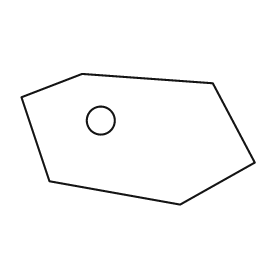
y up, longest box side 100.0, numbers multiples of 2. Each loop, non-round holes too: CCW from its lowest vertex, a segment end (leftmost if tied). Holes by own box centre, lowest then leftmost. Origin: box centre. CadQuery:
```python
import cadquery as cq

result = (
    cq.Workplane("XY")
    .moveTo(18.0, -28.0)
    .lineTo(50.0, -10.0)
    .lineTo(32.0, 24.0)
    .lineTo(-24.0, 28.0)
    .lineTo(-50.0, 18.0)
    .lineTo(-38.0, -18.0)
    .close()
    .moveTo(-16.0, 8.0)
    .circle(6.0)
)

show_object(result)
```